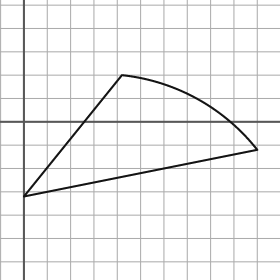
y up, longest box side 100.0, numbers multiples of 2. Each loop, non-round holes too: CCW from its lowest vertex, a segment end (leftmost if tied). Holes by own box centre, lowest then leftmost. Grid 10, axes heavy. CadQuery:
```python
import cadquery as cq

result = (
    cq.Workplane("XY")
    .moveTo(0.0, -32.0)
    .lineTo(100.0, -12.0)
    .threePointArc((74.0, 10.0), (42.0, 20.0))
    .close()
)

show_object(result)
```